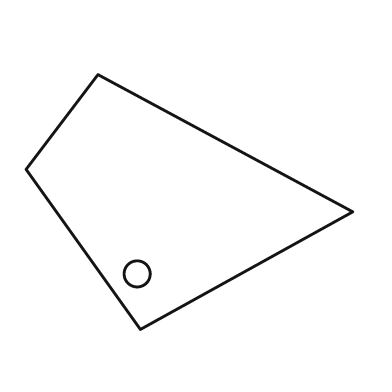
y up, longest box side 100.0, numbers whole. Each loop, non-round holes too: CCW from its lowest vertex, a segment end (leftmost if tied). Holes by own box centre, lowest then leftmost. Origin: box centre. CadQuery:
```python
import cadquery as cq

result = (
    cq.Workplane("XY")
    .moveTo(-15.0, -39.0)
    .lineTo(50.0, -3.0)
    .lineTo(-28.0, 39.0)
    .lineTo(-50.0, 10.0)
    .close()
    .moveTo(-16.0, -22.0)
    .circle(4.0)
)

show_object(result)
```